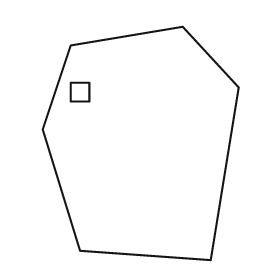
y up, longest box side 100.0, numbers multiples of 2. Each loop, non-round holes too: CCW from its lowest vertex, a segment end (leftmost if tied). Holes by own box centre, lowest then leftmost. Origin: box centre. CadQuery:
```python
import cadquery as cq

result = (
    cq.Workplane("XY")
    .moveTo(30.0, -50.0)
    .lineTo(42.0, 24.0)
    .lineTo(18.0, 50.0)
    .lineTo(-30.0, 42.0)
    .lineTo(-42.0, 6.0)
    .lineTo(-26.0, -46.0)
    .close()
    .moveTo(-30.0, 18.0)
    .lineTo(-22.0, 18.0)
    .lineTo(-22.0, 26.0)
    .lineTo(-30.0, 26.0)
    .close()
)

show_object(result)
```